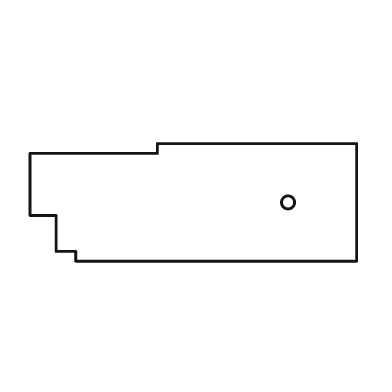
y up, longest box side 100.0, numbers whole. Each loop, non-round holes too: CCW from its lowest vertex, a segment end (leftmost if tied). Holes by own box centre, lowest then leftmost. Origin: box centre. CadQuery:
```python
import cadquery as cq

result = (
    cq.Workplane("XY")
    .moveTo(-36.0, -18.0)
    .lineTo(50.0, -18.0)
    .lineTo(50.0, 18.0)
    .lineTo(-11.0, 18.0)
    .lineTo(-11.0, 15.0)
    .lineTo(-50.0, 15.0)
    .lineTo(-50.0, -4.0)
    .lineTo(-42.0, -4.0)
    .lineTo(-42.0, -15.0)
    .lineTo(-36.0, -15.0)
    .close()
    .moveTo(29.0, 0.0)
    .circle(2.0)
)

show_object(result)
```